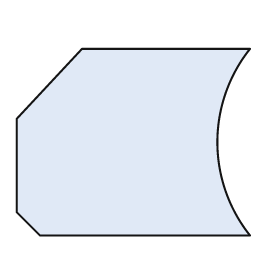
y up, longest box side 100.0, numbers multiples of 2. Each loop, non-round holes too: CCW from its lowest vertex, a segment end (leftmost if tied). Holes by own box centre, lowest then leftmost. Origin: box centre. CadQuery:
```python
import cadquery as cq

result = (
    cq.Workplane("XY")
    .moveTo(-40.0, -40.0)
    .lineTo(50.0, -40.0)
    .threePointArc((36.0, 0.0), (50.0, 40.0))
    .lineTo(-22.0, 40.0)
    .lineTo(-50.0, 10.0)
    .lineTo(-50.0, -30.0)
    .close()
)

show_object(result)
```